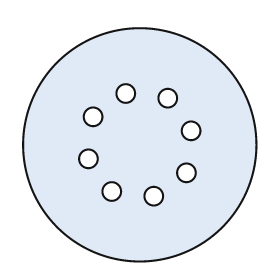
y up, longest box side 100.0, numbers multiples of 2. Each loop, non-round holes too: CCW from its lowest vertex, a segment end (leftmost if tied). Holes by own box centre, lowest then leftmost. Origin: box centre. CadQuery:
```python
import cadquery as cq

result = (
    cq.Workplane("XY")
    .moveTo(0.0, 0.0)
    .circle(50.0)
    .moveTo(6.0, -22.0)
    .circle(4.0)
    .moveTo(-12.0, -20.0)
    .circle(4.0)
    .moveTo(20.0, -12.0)
    .circle(4.0)
    .moveTo(-22.0, -6.0)
    .circle(4.0)
    .moveTo(22.0, 6.0)
    .circle(4.0)
    .moveTo(-20.0, 12.0)
    .circle(4.0)
    .moveTo(12.0, 20.0)
    .circle(4.0)
    .moveTo(-6.0, 22.0)
    .circle(4.0)
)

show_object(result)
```